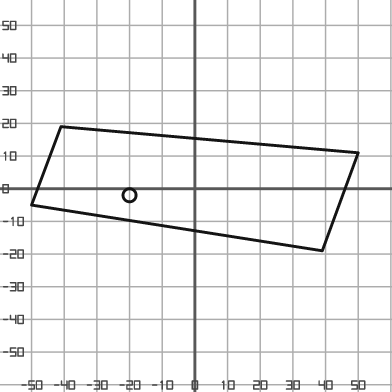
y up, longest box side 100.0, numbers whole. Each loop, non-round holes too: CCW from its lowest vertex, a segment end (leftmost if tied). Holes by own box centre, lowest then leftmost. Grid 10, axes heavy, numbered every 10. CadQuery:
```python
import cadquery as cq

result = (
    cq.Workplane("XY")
    .moveTo(39.0, -19.0)
    .lineTo(50.0, 11.0)
    .lineTo(-41.0, 19.0)
    .lineTo(-50.0, -5.0)
    .close()
    .moveTo(-20.0, -2.0)
    .circle(2.0)
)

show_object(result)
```